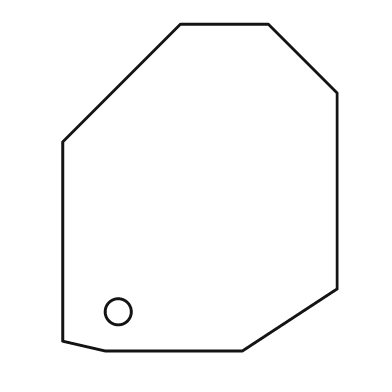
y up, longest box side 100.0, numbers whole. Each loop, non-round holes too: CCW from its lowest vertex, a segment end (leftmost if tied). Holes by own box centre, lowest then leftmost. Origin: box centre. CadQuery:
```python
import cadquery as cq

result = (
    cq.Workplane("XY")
    .moveTo(-29.0, -50.0)
    .lineTo(13.0, -50.0)
    .lineTo(42.0, -31.0)
    .lineTo(42.0, 29.0)
    .lineTo(21.0, 50.0)
    .lineTo(-6.0, 50.0)
    .lineTo(-42.0, 14.0)
    .lineTo(-42.0, -47.0)
    .close()
    .moveTo(-25.0, -38.0)
    .circle(4.0)
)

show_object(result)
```